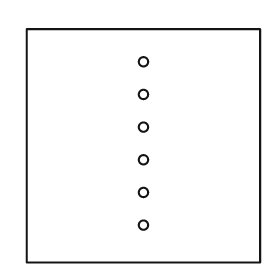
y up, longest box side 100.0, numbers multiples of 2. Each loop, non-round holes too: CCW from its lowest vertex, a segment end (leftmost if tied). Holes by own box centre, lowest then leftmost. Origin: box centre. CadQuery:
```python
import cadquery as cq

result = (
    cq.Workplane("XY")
    .moveTo(-50.0, -50.0)
    .lineTo(50.0, -50.0)
    .lineTo(50.0, 50.0)
    .lineTo(-50.0, 50.0)
    .close()
    .moveTo(0.0, -34.0)
    .circle(2.0)
    .moveTo(0.0, -20.0)
    .circle(2.0)
    .moveTo(0.0, -6.0)
    .circle(2.0)
    .moveTo(0.0, 8.0)
    .circle(2.0)
    .moveTo(0.0, 22.0)
    .circle(2.0)
    .moveTo(0.0, 36.0)
    .circle(2.0)
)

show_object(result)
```